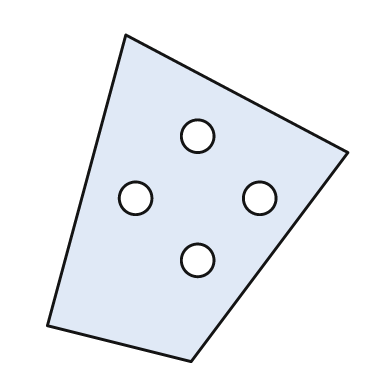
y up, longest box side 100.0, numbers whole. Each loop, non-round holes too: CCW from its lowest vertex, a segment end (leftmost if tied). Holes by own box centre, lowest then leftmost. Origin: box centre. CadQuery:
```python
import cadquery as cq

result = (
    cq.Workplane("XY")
    .moveTo(-2.0, -50.0)
    .lineTo(46.0, 14.0)
    .lineTo(-22.0, 50.0)
    .lineTo(-46.0, -39.0)
    .close()
    .moveTo(0.0, -19.0)
    .circle(5.0)
    .moveTo(-19.0, 0.0)
    .circle(5.0)
    .moveTo(19.0, 0.0)
    .circle(5.0)
    .moveTo(0.0, 19.0)
    .circle(5.0)
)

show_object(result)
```